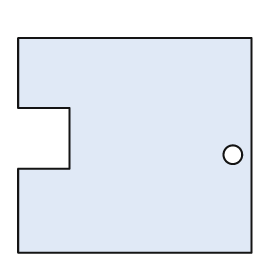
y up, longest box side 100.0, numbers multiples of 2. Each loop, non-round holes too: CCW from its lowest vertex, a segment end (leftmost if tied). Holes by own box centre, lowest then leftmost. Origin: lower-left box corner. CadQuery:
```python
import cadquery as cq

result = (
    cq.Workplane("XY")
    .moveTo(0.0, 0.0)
    .lineTo(100.0, 0.0)
    .lineTo(100.0, 92.0)
    .lineTo(0.0, 92.0)
    .lineTo(0.0, 62.0)
    .lineTo(22.0, 62.0)
    .lineTo(22.0, 36.0)
    .lineTo(0.0, 36.0)
    .close()
    .moveTo(92.0, 42.0)
    .circle(4.0)
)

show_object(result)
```